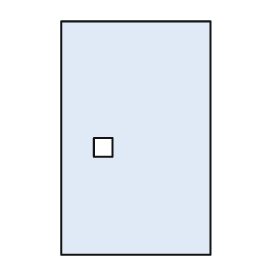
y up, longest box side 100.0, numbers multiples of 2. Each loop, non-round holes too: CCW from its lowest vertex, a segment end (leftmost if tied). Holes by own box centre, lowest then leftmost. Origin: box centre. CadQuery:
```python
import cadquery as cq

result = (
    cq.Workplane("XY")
    .moveTo(-32.0, -50.0)
    .lineTo(32.0, -50.0)
    .lineTo(32.0, 50.0)
    .lineTo(-32.0, 50.0)
    .close()
    .moveTo(-18.0, -8.0)
    .lineTo(-10.0, -8.0)
    .lineTo(-10.0, 0.0)
    .lineTo(-18.0, 0.0)
    .close()
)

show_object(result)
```